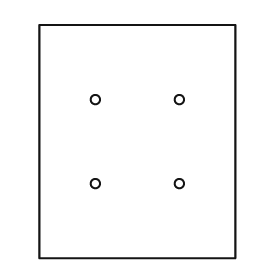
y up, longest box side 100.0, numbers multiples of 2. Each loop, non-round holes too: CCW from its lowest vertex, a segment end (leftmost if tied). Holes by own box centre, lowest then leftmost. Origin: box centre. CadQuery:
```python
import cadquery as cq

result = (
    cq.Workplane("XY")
    .moveTo(-42.0, -50.0)
    .lineTo(42.0, -50.0)
    .lineTo(42.0, 50.0)
    .lineTo(-42.0, 50.0)
    .close()
    .moveTo(-18.0, -18.0)
    .circle(2.0)
    .moveTo(18.0, -18.0)
    .circle(2.0)
    .moveTo(-18.0, 18.0)
    .circle(2.0)
    .moveTo(18.0, 18.0)
    .circle(2.0)
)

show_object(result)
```